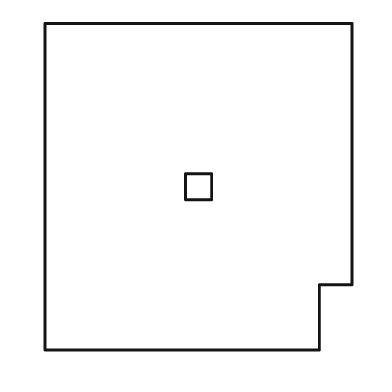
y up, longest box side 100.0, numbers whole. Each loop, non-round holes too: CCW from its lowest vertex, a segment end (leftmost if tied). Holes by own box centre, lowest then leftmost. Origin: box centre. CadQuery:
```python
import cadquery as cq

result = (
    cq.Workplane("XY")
    .moveTo(-47.0, -50.0)
    .lineTo(37.0, -50.0)
    .lineTo(37.0, -30.0)
    .lineTo(47.0, -30.0)
    .lineTo(47.0, 50.0)
    .lineTo(-47.0, 50.0)
    .close()
    .moveTo(-4.0, -4.0)
    .lineTo(4.0, -4.0)
    .lineTo(4.0, 4.0)
    .lineTo(-4.0, 4.0)
    .close()
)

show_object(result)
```